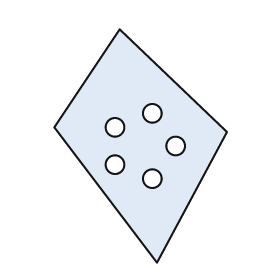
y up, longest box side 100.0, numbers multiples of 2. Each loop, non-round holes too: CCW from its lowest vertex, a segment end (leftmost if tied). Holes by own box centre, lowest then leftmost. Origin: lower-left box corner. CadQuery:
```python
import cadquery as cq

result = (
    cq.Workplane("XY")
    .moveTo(44.0, 0.0)
    .lineTo(74.0, 56.0)
    .lineTo(28.0, 100.0)
    .lineTo(0.0, 58.0)
    .close()
    .moveTo(42.0, 36.0)
    .circle(4.0)
    .moveTo(26.0, 42.0)
    .circle(4.0)
    .moveTo(52.0, 50.0)
    .circle(4.0)
    .moveTo(26.0, 58.0)
    .circle(4.0)
    .moveTo(42.0, 64.0)
    .circle(4.0)
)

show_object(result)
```